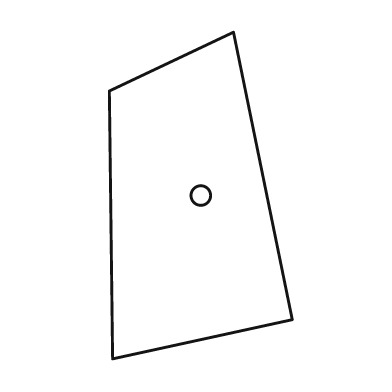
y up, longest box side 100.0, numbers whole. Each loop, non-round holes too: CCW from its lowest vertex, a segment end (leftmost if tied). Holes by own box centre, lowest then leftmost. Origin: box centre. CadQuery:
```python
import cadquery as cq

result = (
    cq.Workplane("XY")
    .moveTo(-27.0, -50.0)
    .lineTo(28.0, -38.0)
    .lineTo(10.0, 50.0)
    .lineTo(-28.0, 32.0)
    .close()
    .moveTo(0.0, 0.0)
    .circle(3.0)
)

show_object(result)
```